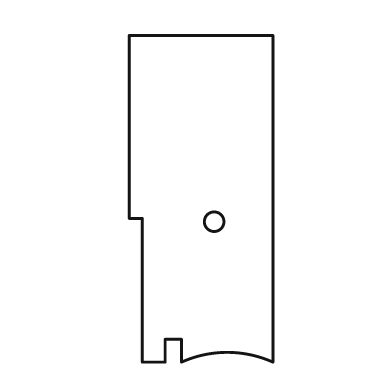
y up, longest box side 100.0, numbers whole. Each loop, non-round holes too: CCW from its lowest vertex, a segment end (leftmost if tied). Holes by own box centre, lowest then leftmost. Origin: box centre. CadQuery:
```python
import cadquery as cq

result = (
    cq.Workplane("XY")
    .moveTo(-18.0, -50.0)
    .lineTo(-11.0, -50.0)
    .lineTo(-11.0, -43.0)
    .lineTo(-6.0, -43.0)
    .lineTo(-6.0, -50.0)
    .threePointArc((8.0, -47.0), (22.0, -50.0))
    .lineTo(22.0, 50.0)
    .lineTo(-22.0, 50.0)
    .lineTo(-22.0, -6.0)
    .lineTo(-18.0, -6.0)
    .close()
    .moveTo(4.0, -7.0)
    .circle(3.0)
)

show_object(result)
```